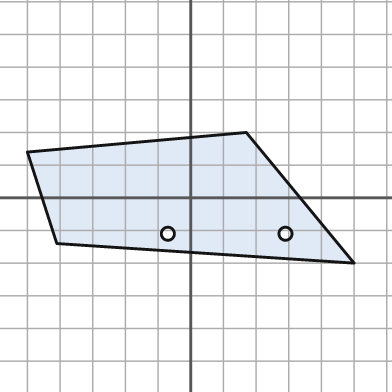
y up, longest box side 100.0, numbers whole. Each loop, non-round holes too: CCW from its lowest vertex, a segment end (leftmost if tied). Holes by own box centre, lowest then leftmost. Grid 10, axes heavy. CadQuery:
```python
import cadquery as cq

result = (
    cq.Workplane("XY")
    .moveTo(50.0, -20.0)
    .lineTo(17.0, 20.0)
    .lineTo(-50.0, 14.0)
    .lineTo(-41.0, -14.0)
    .close()
    .moveTo(-7.0, -11.0)
    .circle(2.0)
    .moveTo(29.0, -11.0)
    .circle(2.0)
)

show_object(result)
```